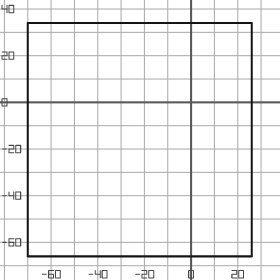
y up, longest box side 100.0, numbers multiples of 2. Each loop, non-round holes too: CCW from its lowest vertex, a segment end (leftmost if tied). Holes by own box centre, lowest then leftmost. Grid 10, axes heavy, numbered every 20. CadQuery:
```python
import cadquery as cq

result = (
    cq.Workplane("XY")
    .moveTo(-70.0, -66.0)
    .lineTo(26.0, -66.0)
    .lineTo(26.0, 34.0)
    .lineTo(-70.0, 34.0)
    .close()
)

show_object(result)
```